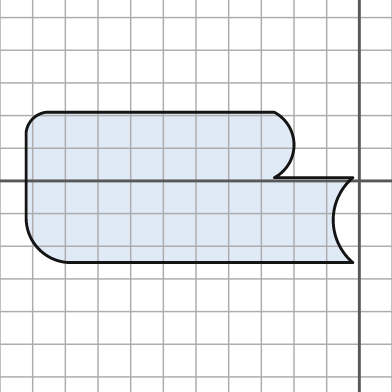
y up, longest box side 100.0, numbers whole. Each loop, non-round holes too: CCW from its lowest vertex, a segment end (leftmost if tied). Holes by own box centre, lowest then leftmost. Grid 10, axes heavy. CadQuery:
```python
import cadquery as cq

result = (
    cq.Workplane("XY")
    .moveTo(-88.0, -25.0)
    .lineTo(-2.0, -25.0)
    .threePointArc((-8.0, -12.0), (-2.0, 1.0))
    .lineTo(-26.0, 1.0)
    .threePointArc((-20.0, 11.0), (-26.0, 21.0))
    .lineTo(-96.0, 21.0)
    .threePointArc((-100.0, 19.0), (-102.0, 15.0))
    .lineTo(-102.0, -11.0)
    .threePointArc((-98.0, -21.0), (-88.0, -25.0))
    .close()
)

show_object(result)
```